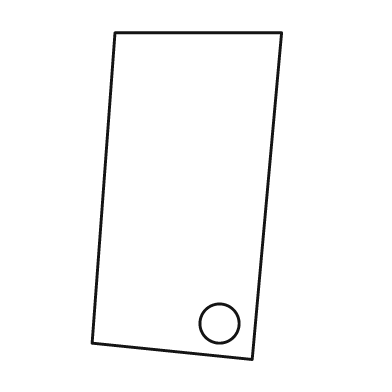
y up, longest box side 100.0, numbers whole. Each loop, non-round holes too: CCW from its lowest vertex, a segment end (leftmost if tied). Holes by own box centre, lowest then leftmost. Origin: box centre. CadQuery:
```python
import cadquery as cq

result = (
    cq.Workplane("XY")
    .moveTo(20.0, -50.0)
    .lineTo(29.0, 50.0)
    .lineTo(-22.0, 50.0)
    .lineTo(-29.0, -45.0)
    .close()
    .moveTo(10.0, -39.0)
    .circle(6.0)
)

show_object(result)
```